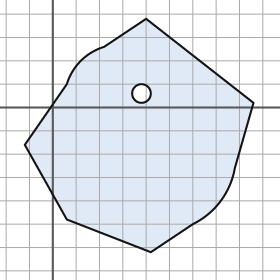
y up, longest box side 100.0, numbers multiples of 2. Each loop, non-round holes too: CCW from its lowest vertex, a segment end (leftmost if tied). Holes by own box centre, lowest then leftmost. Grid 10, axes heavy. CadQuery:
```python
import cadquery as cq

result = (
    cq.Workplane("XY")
    .moveTo(42.0, -62.0)
    .lineTo(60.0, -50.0)
    .threePointArc((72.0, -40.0), (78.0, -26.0))
    .lineTo(86.0, 2.0)
    .lineTo(40.0, 38.0)
    .lineTo(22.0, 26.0)
    .threePointArc((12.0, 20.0), (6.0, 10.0))
    .lineTo(-12.0, -16.0)
    .lineTo(6.0, -48.0)
    .close()
    .moveTo(38.0, 6.0)
    .circle(4.0)
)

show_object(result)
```